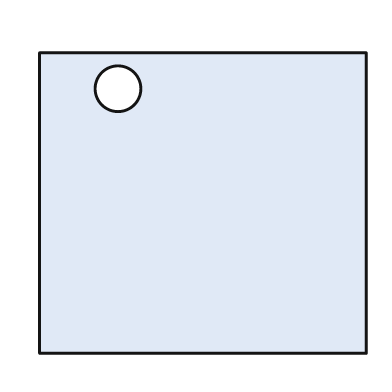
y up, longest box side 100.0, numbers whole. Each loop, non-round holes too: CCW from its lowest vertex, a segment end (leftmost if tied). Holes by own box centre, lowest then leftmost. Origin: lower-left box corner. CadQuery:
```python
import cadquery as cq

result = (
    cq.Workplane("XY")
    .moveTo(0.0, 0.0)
    .lineTo(100.0, 0.0)
    .lineTo(100.0, 92.0)
    .lineTo(0.0, 92.0)
    .close()
    .moveTo(24.0, 81.0)
    .circle(7.0)
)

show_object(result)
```